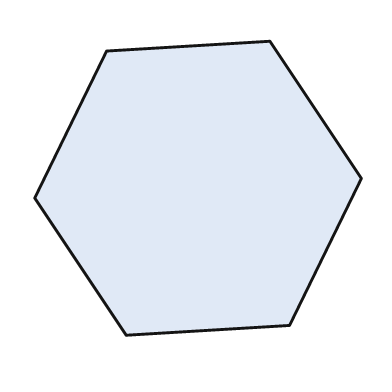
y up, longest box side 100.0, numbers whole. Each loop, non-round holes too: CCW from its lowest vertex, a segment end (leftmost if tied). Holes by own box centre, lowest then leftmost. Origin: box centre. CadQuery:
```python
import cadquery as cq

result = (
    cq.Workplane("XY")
    .moveTo(-22.0, -45.0)
    .lineTo(28.0, -42.0)
    .lineTo(50.0, 3.0)
    .lineTo(22.0, 45.0)
    .lineTo(-28.0, 42.0)
    .lineTo(-50.0, -3.0)
    .close()
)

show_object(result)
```